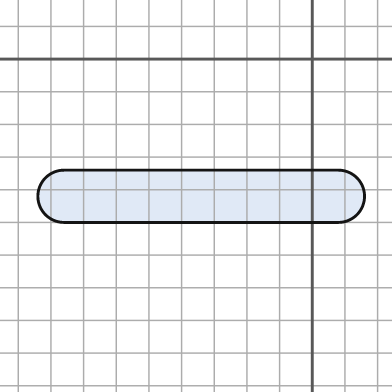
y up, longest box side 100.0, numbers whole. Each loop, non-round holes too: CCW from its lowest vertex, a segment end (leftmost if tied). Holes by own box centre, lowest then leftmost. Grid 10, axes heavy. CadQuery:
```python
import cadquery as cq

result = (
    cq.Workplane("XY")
    .moveTo(-76.0, -50.0)
    .lineTo(8.0, -50.0)
    .threePointArc((16.0, -42.0), (8.0, -34.0))
    .lineTo(-76.0, -34.0)
    .threePointArc((-84.0, -42.0), (-76.0, -50.0))
    .close()
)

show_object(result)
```